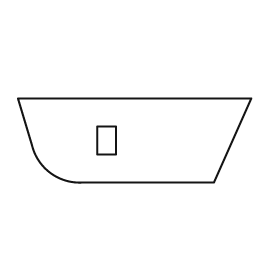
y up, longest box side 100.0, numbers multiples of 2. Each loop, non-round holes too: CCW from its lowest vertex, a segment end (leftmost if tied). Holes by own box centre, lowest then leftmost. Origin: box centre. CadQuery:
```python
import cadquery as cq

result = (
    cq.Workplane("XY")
    .moveTo(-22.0, -18.0)
    .lineTo(34.0, -18.0)
    .lineTo(50.0, 18.0)
    .lineTo(-50.0, 18.0)
    .lineTo(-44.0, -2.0)
    .threePointArc((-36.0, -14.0), (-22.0, -18.0))
    .close()
    .moveTo(-16.0, -6.0)
    .lineTo(-8.0, -6.0)
    .lineTo(-8.0, 6.0)
    .lineTo(-16.0, 6.0)
    .close()
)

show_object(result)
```